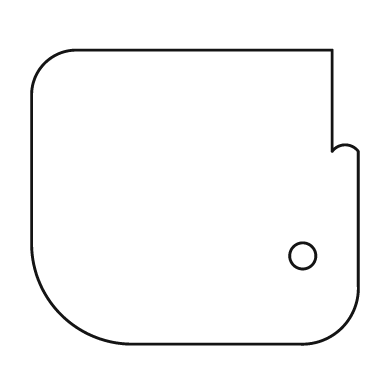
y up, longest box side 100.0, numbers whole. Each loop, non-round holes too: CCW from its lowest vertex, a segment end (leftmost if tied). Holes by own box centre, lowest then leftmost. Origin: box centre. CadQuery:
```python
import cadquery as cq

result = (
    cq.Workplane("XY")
    .moveTo(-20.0, -45.0)
    .lineTo(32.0, -45.0)
    .threePointArc((45.0, -40.0), (50.0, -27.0))
    .lineTo(50.0, 14.0)
    .threePointArc((46.0, 16.0), (42.0, 14.0))
    .lineTo(42.0, 45.0)
    .lineTo(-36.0, 45.0)
    .threePointArc((-46.0, 41.0), (-50.0, 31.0))
    .lineTo(-50.0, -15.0)
    .threePointArc((-41.0, -36.0), (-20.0, -45.0))
    .close()
    .moveTo(33.0, -18.0)
    .circle(4.0)
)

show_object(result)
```